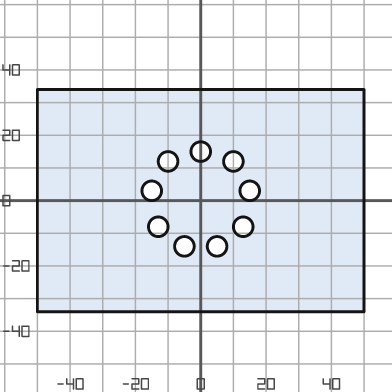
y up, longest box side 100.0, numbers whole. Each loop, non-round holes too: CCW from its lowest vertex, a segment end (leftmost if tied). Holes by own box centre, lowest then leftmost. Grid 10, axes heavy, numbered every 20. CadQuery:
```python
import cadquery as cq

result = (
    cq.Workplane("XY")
    .moveTo(-50.0, -34.0)
    .lineTo(50.0, -34.0)
    .lineTo(50.0, 34.0)
    .lineTo(-50.0, 34.0)
    .close()
    .moveTo(-5.0, -14.0)
    .circle(3.0)
    .moveTo(5.0, -14.0)
    .circle(3.0)
    .moveTo(-13.0, -8.0)
    .circle(3.0)
    .moveTo(13.0, -8.0)
    .circle(3.0)
    .moveTo(-15.0, 3.0)
    .circle(3.0)
    .moveTo(15.0, 3.0)
    .circle(3.0)
    .moveTo(-10.0, 12.0)
    .circle(3.0)
    .moveTo(10.0, 12.0)
    .circle(3.0)
    .moveTo(0.0, 15.0)
    .circle(3.0)
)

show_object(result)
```